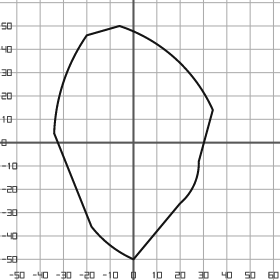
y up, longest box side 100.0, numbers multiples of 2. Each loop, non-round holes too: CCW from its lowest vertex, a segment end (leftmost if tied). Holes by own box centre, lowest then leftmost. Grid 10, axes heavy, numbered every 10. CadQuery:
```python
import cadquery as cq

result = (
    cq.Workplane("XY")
    .moveTo(0.0, -50.0)
    .lineTo(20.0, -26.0)
    .threePointArc((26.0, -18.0), (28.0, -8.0))
    .lineTo(34.0, 14.0)
    .threePointArc((18.0, 36.0), (-6.0, 50.0))
    .lineTo(-20.0, 46.0)
    .threePointArc((-30.0, 26.0), (-34.0, 4.0))
    .lineTo(-18.0, -36.0)
    .threePointArc((-10.0, -44.0), (0.0, -50.0))
    .close()
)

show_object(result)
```